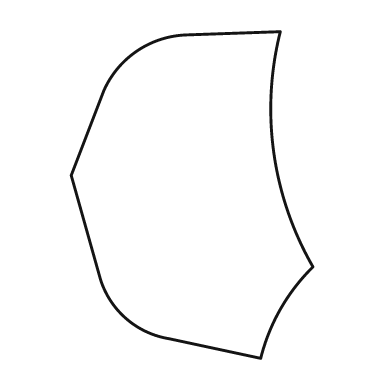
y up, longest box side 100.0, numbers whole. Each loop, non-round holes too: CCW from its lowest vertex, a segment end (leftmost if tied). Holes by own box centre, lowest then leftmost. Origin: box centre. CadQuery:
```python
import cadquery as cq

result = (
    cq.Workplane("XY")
    .moveTo(21.0, -50.0)
    .threePointArc((27.0, -35.0), (37.0, -22.0))
    .threePointArc((25.0, 13.0), (27.0, 50.0))
    .lineTo(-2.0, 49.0)
    .threePointArc((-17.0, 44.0), (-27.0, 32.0))
    .lineTo(-37.0, 6.0)
    .lineTo(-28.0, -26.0)
    .threePointArc((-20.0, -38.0), (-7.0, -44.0))
    .close()
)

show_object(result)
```